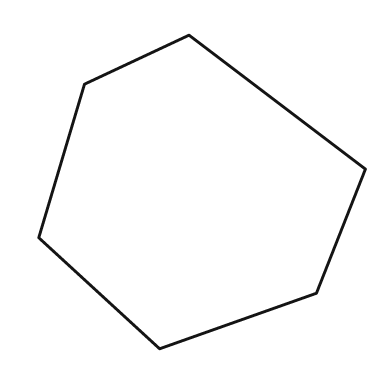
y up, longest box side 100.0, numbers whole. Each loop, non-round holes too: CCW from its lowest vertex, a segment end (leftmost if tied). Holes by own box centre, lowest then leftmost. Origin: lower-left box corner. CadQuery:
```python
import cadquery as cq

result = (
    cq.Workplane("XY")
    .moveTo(37.0, 0.0)
    .lineTo(85.0, 17.0)
    .lineTo(100.0, 55.0)
    .lineTo(46.0, 96.0)
    .lineTo(14.0, 81.0)
    .lineTo(0.0, 34.0)
    .close()
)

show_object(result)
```